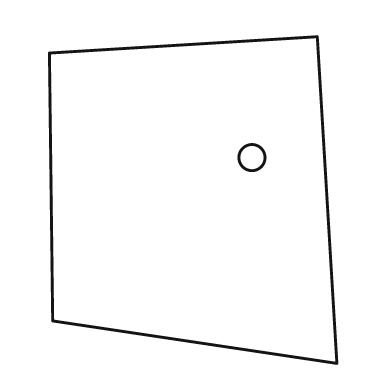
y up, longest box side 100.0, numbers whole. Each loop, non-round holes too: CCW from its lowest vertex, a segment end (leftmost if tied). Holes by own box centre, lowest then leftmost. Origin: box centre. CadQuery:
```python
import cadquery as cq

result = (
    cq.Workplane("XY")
    .moveTo(44.0, -50.0)
    .lineTo(38.0, 50.0)
    .lineTo(-44.0, 45.0)
    .lineTo(-43.0, -37.0)
    .close()
    .moveTo(18.0, 13.0)
    .circle(4.0)
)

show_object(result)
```